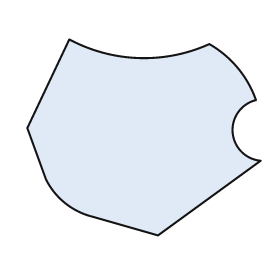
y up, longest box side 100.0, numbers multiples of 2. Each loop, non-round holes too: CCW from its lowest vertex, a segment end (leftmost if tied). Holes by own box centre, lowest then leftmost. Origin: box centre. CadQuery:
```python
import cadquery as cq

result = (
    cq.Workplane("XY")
    .moveTo(6.0, -42.0)
    .lineTo(50.0, -10.0)
    .threePointArc((38.0, 2.0), (48.0, 16.0))
    .threePointArc((40.0, 30.0), (28.0, 40.0))
    .threePointArc((-2.0, 34.0), (-32.0, 42.0))
    .lineTo(-50.0, 4.0)
    .lineTo(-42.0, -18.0)
    .threePointArc((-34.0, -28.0), (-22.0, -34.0))
    .close()
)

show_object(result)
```